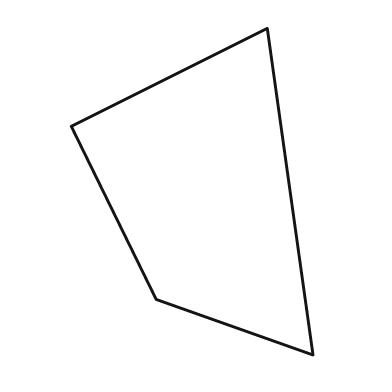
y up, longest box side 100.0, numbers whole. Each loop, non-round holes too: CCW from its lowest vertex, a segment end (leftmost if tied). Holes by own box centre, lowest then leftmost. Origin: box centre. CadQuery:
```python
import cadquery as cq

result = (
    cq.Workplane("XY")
    .moveTo(37.0, -50.0)
    .lineTo(23.0, 50.0)
    .lineTo(-37.0, 20.0)
    .lineTo(-11.0, -33.0)
    .close()
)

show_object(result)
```